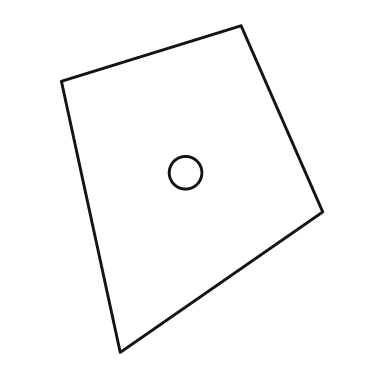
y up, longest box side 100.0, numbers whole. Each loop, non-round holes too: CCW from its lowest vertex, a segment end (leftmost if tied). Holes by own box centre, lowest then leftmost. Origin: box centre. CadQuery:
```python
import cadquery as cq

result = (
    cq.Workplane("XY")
    .moveTo(-22.0, -50.0)
    .lineTo(40.0, -7.0)
    .lineTo(15.0, 50.0)
    .lineTo(-40.0, 33.0)
    .close()
    .moveTo(-2.0, 5.0)
    .circle(5.0)
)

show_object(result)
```